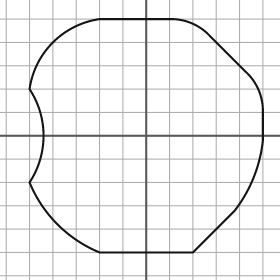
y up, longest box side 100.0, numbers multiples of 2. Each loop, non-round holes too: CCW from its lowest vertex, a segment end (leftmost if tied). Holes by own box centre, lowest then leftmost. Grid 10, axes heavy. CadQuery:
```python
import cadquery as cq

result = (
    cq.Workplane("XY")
    .moveTo(-20.0, -50.0)
    .lineTo(20.0, -50.0)
    .lineTo(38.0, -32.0)
    .threePointArc((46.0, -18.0), (50.0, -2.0))
    .lineTo(50.0, 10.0)
    .threePointArc((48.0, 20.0), (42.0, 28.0))
    .lineTo(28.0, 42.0)
    .threePointArc((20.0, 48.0), (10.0, 50.0))
    .lineTo(-20.0, 50.0)
    .threePointArc((-40.0, 40.0), (-50.0, 20.0))
    .threePointArc((-44.0, 0.0), (-50.0, -20.0))
    .threePointArc((-38.0, -38.0), (-20.0, -50.0))
    .close()
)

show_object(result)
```